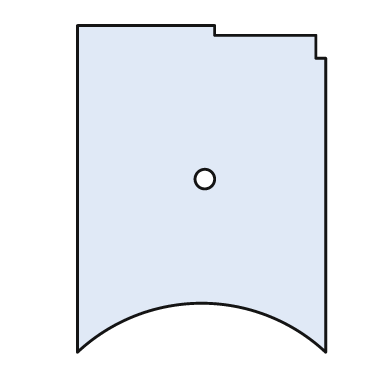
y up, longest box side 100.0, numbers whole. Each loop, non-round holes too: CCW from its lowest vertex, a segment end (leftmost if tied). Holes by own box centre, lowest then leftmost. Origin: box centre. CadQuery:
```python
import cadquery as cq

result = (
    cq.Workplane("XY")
    .moveTo(-38.0, -50.0)
    .threePointArc((0.0, -35.0), (38.0, -50.0))
    .lineTo(38.0, 40.0)
    .lineTo(35.0, 40.0)
    .lineTo(35.0, 47.0)
    .lineTo(4.0, 47.0)
    .lineTo(4.0, 50.0)
    .lineTo(-38.0, 50.0)
    .close()
    .moveTo(1.0, 3.0)
    .circle(3.0)
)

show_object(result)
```